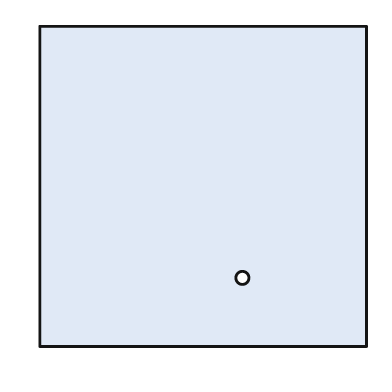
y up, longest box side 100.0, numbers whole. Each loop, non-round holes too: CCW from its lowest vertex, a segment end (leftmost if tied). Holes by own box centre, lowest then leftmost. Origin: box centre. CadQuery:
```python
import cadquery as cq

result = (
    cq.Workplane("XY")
    .moveTo(-50.0, -49.0)
    .lineTo(50.0, -49.0)
    .lineTo(50.0, 49.0)
    .lineTo(-50.0, 49.0)
    .close()
    .moveTo(12.0, -28.0)
    .circle(2.0)
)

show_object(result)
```